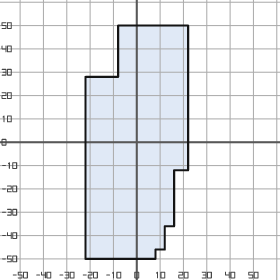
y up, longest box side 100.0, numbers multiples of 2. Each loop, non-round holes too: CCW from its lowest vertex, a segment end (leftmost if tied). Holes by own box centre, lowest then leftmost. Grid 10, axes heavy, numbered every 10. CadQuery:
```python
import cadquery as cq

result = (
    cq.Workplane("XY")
    .moveTo(-22.0, -50.0)
    .lineTo(8.0, -50.0)
    .lineTo(8.0, -46.0)
    .lineTo(12.0, -46.0)
    .lineTo(12.0, -36.0)
    .lineTo(16.0, -36.0)
    .lineTo(16.0, -12.0)
    .lineTo(22.0, -12.0)
    .lineTo(22.0, 50.0)
    .lineTo(-8.0, 50.0)
    .lineTo(-8.0, 28.0)
    .lineTo(-22.0, 28.0)
    .close()
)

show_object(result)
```